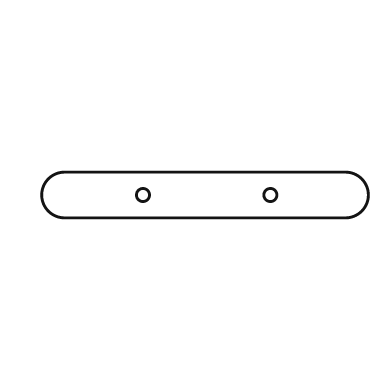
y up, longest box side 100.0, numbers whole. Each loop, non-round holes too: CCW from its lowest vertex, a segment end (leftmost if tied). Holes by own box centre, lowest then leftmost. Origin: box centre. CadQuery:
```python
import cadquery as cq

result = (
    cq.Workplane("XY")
    .moveTo(-43.0, -7.0)
    .lineTo(43.0, -7.0)
    .threePointArc((50.0, 0.0), (43.0, 7.0))
    .lineTo(-43.0, 7.0)
    .threePointArc((-50.0, 0.0), (-43.0, -7.0))
    .close()
    .moveTo(-19.0, 0.0)
    .circle(2.0)
    .moveTo(20.0, 0.0)
    .circle(2.0)
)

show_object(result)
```